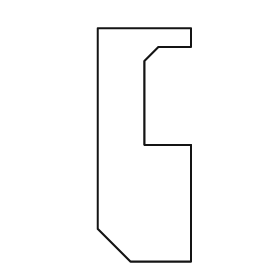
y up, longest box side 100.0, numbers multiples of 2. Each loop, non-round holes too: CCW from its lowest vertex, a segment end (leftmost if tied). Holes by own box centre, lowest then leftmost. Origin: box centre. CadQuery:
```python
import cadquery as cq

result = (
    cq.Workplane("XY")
    .moveTo(-6.0, -50.0)
    .lineTo(20.0, -50.0)
    .lineTo(20.0, 0.0)
    .lineTo(0.0, 0.0)
    .lineTo(0.0, 36.0)
    .lineTo(6.0, 42.0)
    .lineTo(20.0, 42.0)
    .lineTo(20.0, 50.0)
    .lineTo(-20.0, 50.0)
    .lineTo(-20.0, -36.0)
    .close()
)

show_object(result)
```